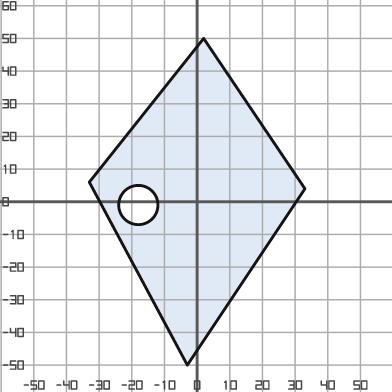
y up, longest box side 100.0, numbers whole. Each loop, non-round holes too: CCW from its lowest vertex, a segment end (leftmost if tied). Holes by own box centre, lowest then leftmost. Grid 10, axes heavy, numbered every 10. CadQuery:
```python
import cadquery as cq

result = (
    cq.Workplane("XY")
    .moveTo(-3.0, -50.0)
    .lineTo(33.0, 4.0)
    .lineTo(2.0, 50.0)
    .lineTo(-33.0, 6.0)
    .close()
    .moveTo(-18.0, -1.0)
    .circle(6.0)
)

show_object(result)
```